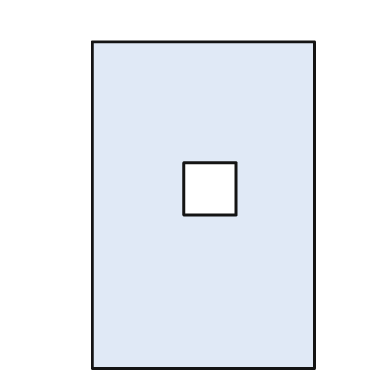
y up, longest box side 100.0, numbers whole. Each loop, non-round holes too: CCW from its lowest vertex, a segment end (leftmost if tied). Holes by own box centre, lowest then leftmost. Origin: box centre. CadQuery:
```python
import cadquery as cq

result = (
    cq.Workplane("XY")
    .moveTo(-34.0, -50.0)
    .lineTo(34.0, -50.0)
    .lineTo(34.0, 50.0)
    .lineTo(-34.0, 50.0)
    .close()
    .moveTo(-6.0, -3.0)
    .lineTo(10.0, -3.0)
    .lineTo(10.0, 13.0)
    .lineTo(-6.0, 13.0)
    .close()
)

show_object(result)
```